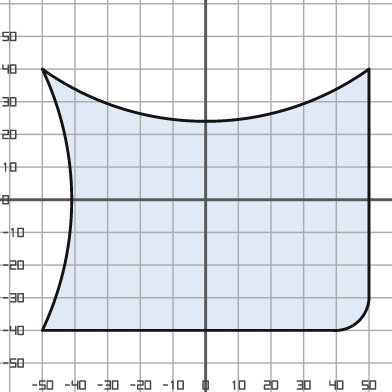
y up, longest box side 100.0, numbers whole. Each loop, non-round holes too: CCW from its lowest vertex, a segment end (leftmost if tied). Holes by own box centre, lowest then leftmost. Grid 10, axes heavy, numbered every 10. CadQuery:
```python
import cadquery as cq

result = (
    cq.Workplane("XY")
    .moveTo(-50.0, -40.0)
    .lineTo(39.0, -40.0)
    .threePointArc((47.0, -37.0), (50.0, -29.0))
    .lineTo(50.0, 40.0)
    .threePointArc((0.0, 24.0), (-50.0, 40.0))
    .threePointArc((-41.0, 0.0), (-50.0, -40.0))
    .close()
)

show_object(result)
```